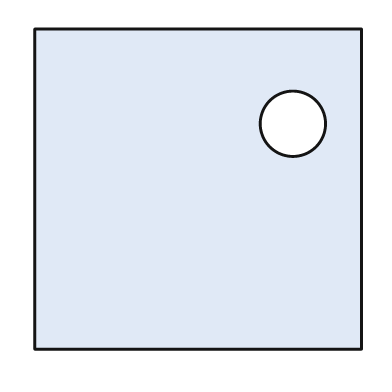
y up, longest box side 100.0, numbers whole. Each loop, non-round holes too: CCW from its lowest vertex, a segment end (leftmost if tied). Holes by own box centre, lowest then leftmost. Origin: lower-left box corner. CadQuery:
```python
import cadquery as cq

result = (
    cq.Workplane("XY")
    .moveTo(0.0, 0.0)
    .lineTo(100.0, 0.0)
    .lineTo(100.0, 98.0)
    .lineTo(0.0, 98.0)
    .close()
    .moveTo(79.0, 69.0)
    .circle(10.0)
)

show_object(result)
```